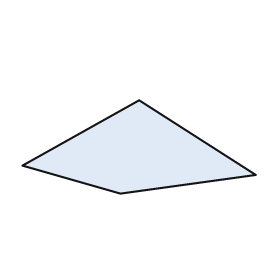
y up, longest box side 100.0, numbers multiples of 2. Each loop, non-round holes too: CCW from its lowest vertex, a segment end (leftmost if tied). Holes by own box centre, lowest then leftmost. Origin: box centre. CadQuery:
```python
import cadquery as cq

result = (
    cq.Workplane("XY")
    .moveTo(-8.0, -20.0)
    .lineTo(50.0, -12.0)
    .lineTo(0.0, 20.0)
    .lineTo(-50.0, -8.0)
    .close()
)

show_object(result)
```